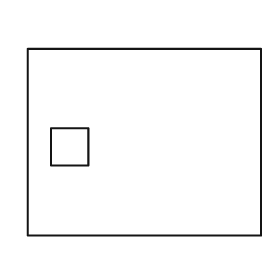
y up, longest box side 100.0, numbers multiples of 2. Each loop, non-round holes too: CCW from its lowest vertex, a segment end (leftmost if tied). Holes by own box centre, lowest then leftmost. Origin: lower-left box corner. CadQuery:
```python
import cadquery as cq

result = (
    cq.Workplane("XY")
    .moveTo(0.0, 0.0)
    .lineTo(100.0, 0.0)
    .lineTo(100.0, 80.0)
    .lineTo(0.0, 80.0)
    .close()
    .moveTo(10.0, 30.0)
    .lineTo(26.0, 30.0)
    .lineTo(26.0, 46.0)
    .lineTo(10.0, 46.0)
    .close()
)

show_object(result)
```